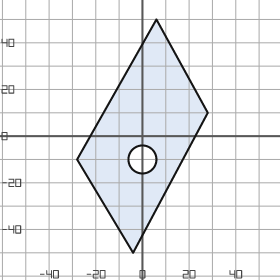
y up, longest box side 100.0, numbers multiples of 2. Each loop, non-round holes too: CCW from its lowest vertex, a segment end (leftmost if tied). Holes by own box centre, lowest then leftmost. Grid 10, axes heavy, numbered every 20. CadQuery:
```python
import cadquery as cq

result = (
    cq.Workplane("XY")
    .moveTo(-4.0, -50.0)
    .lineTo(28.0, 10.0)
    .lineTo(6.0, 50.0)
    .lineTo(-28.0, -10.0)
    .close()
    .moveTo(0.0, -10.0)
    .circle(6.0)
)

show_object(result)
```